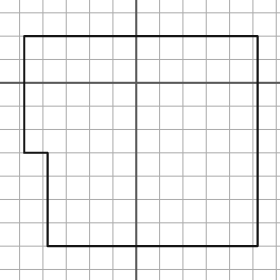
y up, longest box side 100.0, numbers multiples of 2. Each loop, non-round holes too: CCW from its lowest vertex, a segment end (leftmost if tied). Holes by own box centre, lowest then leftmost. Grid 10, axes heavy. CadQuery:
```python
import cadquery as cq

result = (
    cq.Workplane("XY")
    .moveTo(-38.0, -70.0)
    .lineTo(52.0, -70.0)
    .lineTo(52.0, 20.0)
    .lineTo(-48.0, 20.0)
    .lineTo(-48.0, -30.0)
    .lineTo(-38.0, -30.0)
    .close()
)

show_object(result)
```